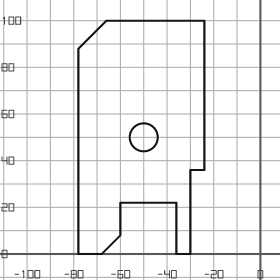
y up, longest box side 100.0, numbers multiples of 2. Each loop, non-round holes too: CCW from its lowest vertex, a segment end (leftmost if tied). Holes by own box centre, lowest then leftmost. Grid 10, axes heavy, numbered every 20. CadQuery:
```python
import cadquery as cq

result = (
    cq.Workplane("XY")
    .moveTo(-78.0, 0.0)
    .lineTo(-68.0, 0.0)
    .lineTo(-60.0, 8.0)
    .lineTo(-60.0, 22.0)
    .lineTo(-36.0, 22.0)
    .lineTo(-36.0, 0.0)
    .lineTo(-30.0, 0.0)
    .lineTo(-30.0, 36.0)
    .lineTo(-24.0, 36.0)
    .lineTo(-24.0, 100.0)
    .lineTo(-66.0, 100.0)
    .lineTo(-78.0, 88.0)
    .close()
    .moveTo(-50.0, 50.0)
    .circle(6.0)
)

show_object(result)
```